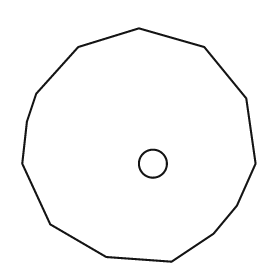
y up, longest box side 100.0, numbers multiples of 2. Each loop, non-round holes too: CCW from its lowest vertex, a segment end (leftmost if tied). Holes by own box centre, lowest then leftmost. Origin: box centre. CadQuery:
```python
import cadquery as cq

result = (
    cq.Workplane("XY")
    .moveTo(14.0, -50.0)
    .lineTo(32.0, -38.0)
    .lineTo(42.0, -26.0)
    .lineTo(50.0, -8.0)
    .lineTo(46.0, 20.0)
    .lineTo(28.0, 42.0)
    .lineTo(0.0, 50.0)
    .lineTo(-26.0, 42.0)
    .lineTo(-44.0, 22.0)
    .lineTo(-48.0, 10.0)
    .lineTo(-50.0, -8.0)
    .lineTo(-38.0, -34.0)
    .lineTo(-14.0, -48.0)
    .close()
    .moveTo(6.0, -8.0)
    .circle(6.0)
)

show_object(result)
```